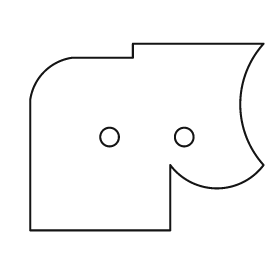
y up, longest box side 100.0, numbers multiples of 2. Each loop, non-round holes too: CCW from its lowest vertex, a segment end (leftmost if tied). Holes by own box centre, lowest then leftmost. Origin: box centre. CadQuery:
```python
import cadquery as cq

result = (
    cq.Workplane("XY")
    .moveTo(-50.0, -40.0)
    .lineTo(10.0, -40.0)
    .lineTo(10.0, -12.0)
    .threePointArc((30.0, -22.0), (50.0, -12.0))
    .threePointArc((40.0, 14.0), (50.0, 40.0))
    .lineTo(-6.0, 40.0)
    .lineTo(-6.0, 34.0)
    .lineTo(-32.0, 34.0)
    .threePointArc((-44.0, 28.0), (-50.0, 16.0))
    .close()
    .moveTo(-16.0, 0.0)
    .circle(4.0)
    .moveTo(16.0, 0.0)
    .circle(4.0)
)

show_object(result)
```